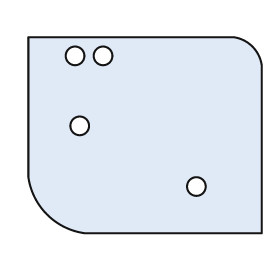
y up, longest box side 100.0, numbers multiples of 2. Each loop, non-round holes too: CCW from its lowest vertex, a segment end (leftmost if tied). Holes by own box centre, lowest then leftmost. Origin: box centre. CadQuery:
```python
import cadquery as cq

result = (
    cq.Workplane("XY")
    .moveTo(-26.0, -42.0)
    .lineTo(50.0, -42.0)
    .lineTo(50.0, 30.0)
    .threePointArc((46.0, 38.0), (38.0, 42.0))
    .lineTo(-50.0, 42.0)
    .lineTo(-50.0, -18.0)
    .threePointArc((-42.0, -34.0), (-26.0, -42.0))
    .close()
    .moveTo(22.0, -22.0)
    .circle(4.0)
    .moveTo(-28.0, 4.0)
    .circle(4.0)
    .moveTo(-30.0, 34.0)
    .circle(4.0)
    .moveTo(-18.0, 34.0)
    .circle(4.0)
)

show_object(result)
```